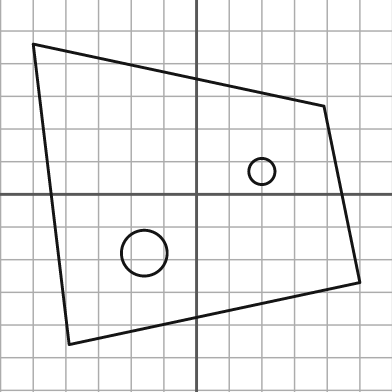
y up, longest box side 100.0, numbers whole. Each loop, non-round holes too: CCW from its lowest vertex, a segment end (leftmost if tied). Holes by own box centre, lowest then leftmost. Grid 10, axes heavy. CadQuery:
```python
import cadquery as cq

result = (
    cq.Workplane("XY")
    .moveTo(-39.0, -46.0)
    .lineTo(50.0, -27.0)
    .lineTo(39.0, 27.0)
    .lineTo(-50.0, 46.0)
    .close()
    .moveTo(-16.0, -18.0)
    .circle(7.0)
    .moveTo(20.0, 7.0)
    .circle(4.0)
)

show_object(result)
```